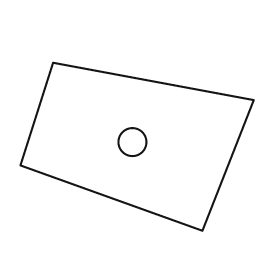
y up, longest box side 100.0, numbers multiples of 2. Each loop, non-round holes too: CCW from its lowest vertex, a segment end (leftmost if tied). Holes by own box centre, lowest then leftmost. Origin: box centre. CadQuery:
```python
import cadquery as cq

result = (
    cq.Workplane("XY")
    .moveTo(28.0, -36.0)
    .lineTo(50.0, 20.0)
    .lineTo(-36.0, 36.0)
    .lineTo(-50.0, -8.0)
    .close()
    .moveTo(-2.0, 2.0)
    .circle(6.0)
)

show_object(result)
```